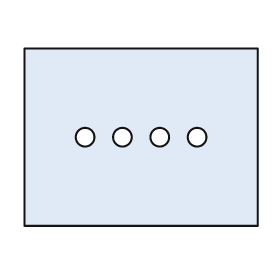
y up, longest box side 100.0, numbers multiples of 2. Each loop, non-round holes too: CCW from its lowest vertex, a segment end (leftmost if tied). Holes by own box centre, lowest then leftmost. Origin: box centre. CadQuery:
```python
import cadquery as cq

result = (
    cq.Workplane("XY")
    .moveTo(-50.0, -38.0)
    .lineTo(50.0, -38.0)
    .lineTo(50.0, 38.0)
    .lineTo(-50.0, 38.0)
    .close()
    .moveTo(-24.0, 0.0)
    .circle(4.0)
    .moveTo(-8.0, 0.0)
    .circle(4.0)
    .moveTo(8.0, 0.0)
    .circle(4.0)
    .moveTo(24.0, 0.0)
    .circle(4.0)
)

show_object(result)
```